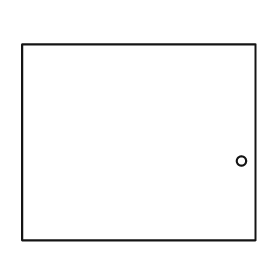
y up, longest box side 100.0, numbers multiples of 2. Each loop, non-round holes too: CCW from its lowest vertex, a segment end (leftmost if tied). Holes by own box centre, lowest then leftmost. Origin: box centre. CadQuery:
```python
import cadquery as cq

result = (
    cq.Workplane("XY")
    .moveTo(-50.0, -42.0)
    .lineTo(50.0, -42.0)
    .lineTo(50.0, 42.0)
    .lineTo(-50.0, 42.0)
    .close()
    .moveTo(44.0, -8.0)
    .circle(2.0)
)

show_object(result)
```